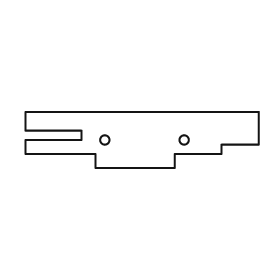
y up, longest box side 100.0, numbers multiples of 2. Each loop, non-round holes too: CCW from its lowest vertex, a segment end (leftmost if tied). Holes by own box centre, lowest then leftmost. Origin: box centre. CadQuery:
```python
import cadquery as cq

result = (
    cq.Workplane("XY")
    .moveTo(-20.0, -12.0)
    .lineTo(14.0, -12.0)
    .lineTo(14.0, -6.0)
    .lineTo(34.0, -6.0)
    .lineTo(34.0, -2.0)
    .lineTo(50.0, -2.0)
    .lineTo(50.0, 12.0)
    .lineTo(-50.0, 12.0)
    .lineTo(-50.0, 4.0)
    .lineTo(-26.0, 4.0)
    .lineTo(-26.0, 0.0)
    .lineTo(-50.0, 0.0)
    .lineTo(-50.0, -6.0)
    .lineTo(-20.0, -6.0)
    .close()
    .moveTo(-16.0, 0.0)
    .circle(2.0)
    .moveTo(18.0, 0.0)
    .circle(2.0)
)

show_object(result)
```